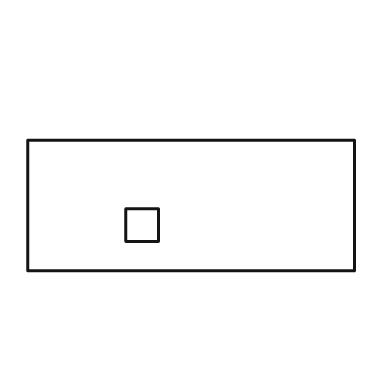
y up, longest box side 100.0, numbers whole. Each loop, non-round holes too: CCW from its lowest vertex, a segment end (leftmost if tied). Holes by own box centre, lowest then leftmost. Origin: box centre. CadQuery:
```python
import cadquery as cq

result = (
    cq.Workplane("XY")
    .moveTo(-50.0, -20.0)
    .lineTo(50.0, -20.0)
    .lineTo(50.0, 20.0)
    .lineTo(-50.0, 20.0)
    .close()
    .moveTo(-20.0, -11.0)
    .lineTo(-10.0, -11.0)
    .lineTo(-10.0, -1.0)
    .lineTo(-20.0, -1.0)
    .close()
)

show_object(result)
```